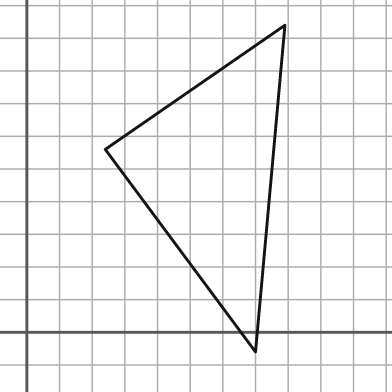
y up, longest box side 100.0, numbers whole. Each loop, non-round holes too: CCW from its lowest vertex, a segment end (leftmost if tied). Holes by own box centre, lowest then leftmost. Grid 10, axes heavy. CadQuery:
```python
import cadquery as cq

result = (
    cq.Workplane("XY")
    .moveTo(70.0, -6.0)
    .lineTo(79.0, 94.0)
    .lineTo(24.0, 56.0)
    .close()
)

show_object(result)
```